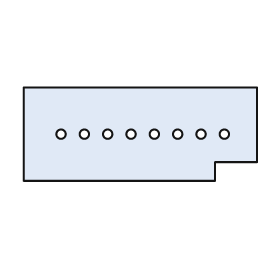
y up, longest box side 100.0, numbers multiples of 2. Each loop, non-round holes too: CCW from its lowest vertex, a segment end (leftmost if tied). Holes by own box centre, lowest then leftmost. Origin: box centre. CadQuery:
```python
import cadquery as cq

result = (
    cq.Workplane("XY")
    .moveTo(-50.0, -20.0)
    .lineTo(32.0, -20.0)
    .lineTo(32.0, -12.0)
    .lineTo(50.0, -12.0)
    .lineTo(50.0, 20.0)
    .lineTo(-50.0, 20.0)
    .close()
    .moveTo(-34.0, 0.0)
    .circle(2.0)
    .moveTo(-24.0, 0.0)
    .circle(2.0)
    .moveTo(-14.0, 0.0)
    .circle(2.0)
    .moveTo(-4.0, 0.0)
    .circle(2.0)
    .moveTo(6.0, 0.0)
    .circle(2.0)
    .moveTo(16.0, 0.0)
    .circle(2.0)
    .moveTo(26.0, 0.0)
    .circle(2.0)
    .moveTo(36.0, 0.0)
    .circle(2.0)
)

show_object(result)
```